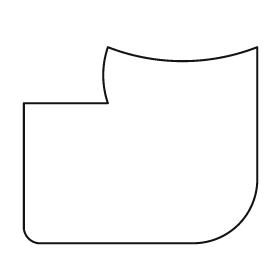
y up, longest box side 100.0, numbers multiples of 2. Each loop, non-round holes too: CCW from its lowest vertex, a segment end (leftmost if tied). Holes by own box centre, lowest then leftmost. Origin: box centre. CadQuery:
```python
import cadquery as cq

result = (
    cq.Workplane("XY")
    .moveTo(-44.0, -42.0)
    .lineTo(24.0, -42.0)
    .threePointArc((42.0, -34.0), (50.0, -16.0))
    .lineTo(50.0, 42.0)
    .threePointArc((18.0, 36.0), (-14.0, 42.0))
    .threePointArc((-16.0, 30.0), (-14.0, 18.0))
    .lineTo(-50.0, 18.0)
    .lineTo(-50.0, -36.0)
    .threePointArc((-48.0, -40.0), (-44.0, -42.0))
    .close()
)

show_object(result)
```